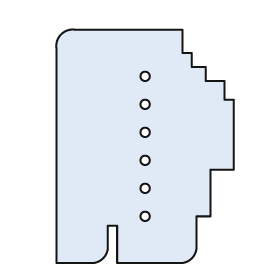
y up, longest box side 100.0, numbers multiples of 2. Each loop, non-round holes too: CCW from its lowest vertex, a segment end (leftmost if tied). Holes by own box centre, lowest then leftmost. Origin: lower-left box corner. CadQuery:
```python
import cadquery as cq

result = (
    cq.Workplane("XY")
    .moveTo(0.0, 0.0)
    .lineTo(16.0, 0.0)
    .threePointArc((20.0, 2.0), (22.0, 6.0))
    .lineTo(22.0, 16.0)
    .lineTo(26.0, 16.0)
    .lineTo(26.0, 0.0)
    .lineTo(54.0, 0.0)
    .threePointArc((58.0, 2.0), (60.0, 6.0))
    .lineTo(60.0, 20.0)
    .lineTo(66.0, 20.0)
    .lineTo(66.0, 40.0)
    .lineTo(76.0, 40.0)
    .lineTo(76.0, 70.0)
    .lineTo(72.0, 70.0)
    .lineTo(72.0, 78.0)
    .lineTo(64.0, 78.0)
    .lineTo(64.0, 84.0)
    .lineTo(58.0, 84.0)
    .lineTo(58.0, 90.0)
    .lineTo(54.0, 90.0)
    .lineTo(54.0, 100.0)
    .lineTo(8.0, 100.0)
    .threePointArc((2.0, 98.0), (0.0, 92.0))
    .close()
    .moveTo(38.0, 20.0)
    .circle(2.0)
    .moveTo(38.0, 32.0)
    .circle(2.0)
    .moveTo(38.0, 44.0)
    .circle(2.0)
    .moveTo(38.0, 56.0)
    .circle(2.0)
    .moveTo(38.0, 68.0)
    .circle(2.0)
    .moveTo(38.0, 80.0)
    .circle(2.0)
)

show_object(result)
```